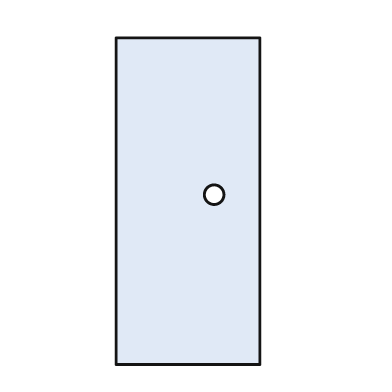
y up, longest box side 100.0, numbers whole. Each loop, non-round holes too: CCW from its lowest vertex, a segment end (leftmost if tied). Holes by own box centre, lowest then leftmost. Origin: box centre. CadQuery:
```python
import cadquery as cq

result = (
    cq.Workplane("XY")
    .moveTo(-22.0, -50.0)
    .lineTo(22.0, -50.0)
    .lineTo(22.0, 50.0)
    .lineTo(-22.0, 50.0)
    .close()
    .moveTo(8.0, 2.0)
    .circle(3.0)
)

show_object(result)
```